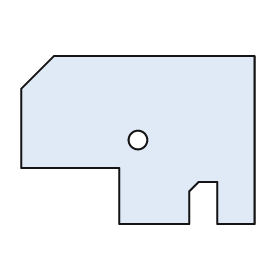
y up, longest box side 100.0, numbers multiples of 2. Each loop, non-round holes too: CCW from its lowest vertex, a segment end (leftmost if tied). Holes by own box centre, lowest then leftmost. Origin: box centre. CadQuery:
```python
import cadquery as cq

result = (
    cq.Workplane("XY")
    .moveTo(-8.0, -36.0)
    .lineTo(22.0, -36.0)
    .lineTo(22.0, -22.0)
    .lineTo(26.0, -18.0)
    .lineTo(34.0, -18.0)
    .lineTo(34.0, -36.0)
    .lineTo(50.0, -36.0)
    .lineTo(50.0, 36.0)
    .lineTo(-36.0, 36.0)
    .lineTo(-50.0, 22.0)
    .lineTo(-50.0, -12.0)
    .lineTo(-8.0, -12.0)
    .close()
    .moveTo(0.0, 0.0)
    .circle(4.0)
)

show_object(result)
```